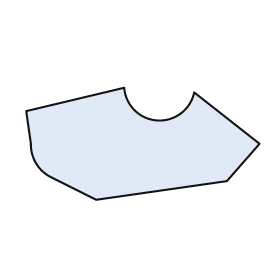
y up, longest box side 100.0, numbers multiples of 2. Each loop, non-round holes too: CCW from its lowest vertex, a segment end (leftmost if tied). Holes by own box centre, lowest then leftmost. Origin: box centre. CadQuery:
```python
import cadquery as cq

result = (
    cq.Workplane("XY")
    .moveTo(-20.0, -24.0)
    .lineTo(36.0, -16.0)
    .lineTo(50.0, 0.0)
    .lineTo(22.0, 22.0)
    .threePointArc((6.0, 10.0), (-8.0, 24.0))
    .lineTo(-50.0, 14.0)
    .lineTo(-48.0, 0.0)
    .threePointArc((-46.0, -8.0), (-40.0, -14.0))
    .close()
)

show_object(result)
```